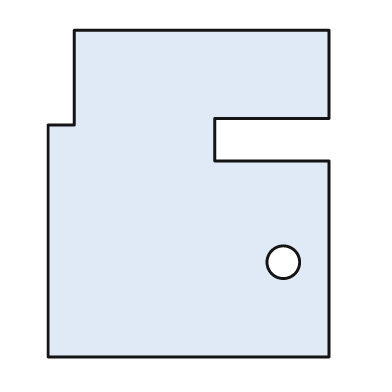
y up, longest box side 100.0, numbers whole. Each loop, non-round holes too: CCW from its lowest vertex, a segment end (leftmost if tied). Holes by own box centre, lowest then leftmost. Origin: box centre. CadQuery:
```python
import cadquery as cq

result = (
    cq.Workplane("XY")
    .moveTo(-43.0, -50.0)
    .lineTo(43.0, -50.0)
    .lineTo(43.0, 10.0)
    .lineTo(8.0, 10.0)
    .lineTo(8.0, 23.0)
    .lineTo(43.0, 23.0)
    .lineTo(43.0, 50.0)
    .lineTo(-35.0, 50.0)
    .lineTo(-35.0, 21.0)
    .lineTo(-43.0, 21.0)
    .close()
    .moveTo(29.0, -21.0)
    .circle(5.0)
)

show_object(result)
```